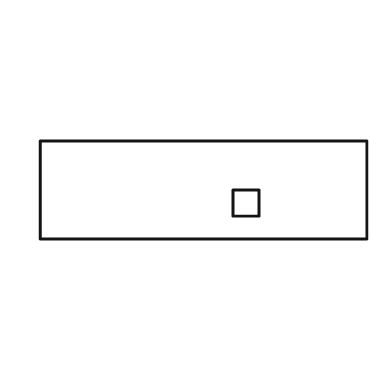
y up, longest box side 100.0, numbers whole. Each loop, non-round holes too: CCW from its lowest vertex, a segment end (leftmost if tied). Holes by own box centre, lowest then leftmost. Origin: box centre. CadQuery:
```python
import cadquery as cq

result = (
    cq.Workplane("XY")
    .moveTo(-50.0, -15.0)
    .lineTo(50.0, -15.0)
    .lineTo(50.0, 15.0)
    .lineTo(-50.0, 15.0)
    .close()
    .moveTo(9.0, -8.0)
    .lineTo(17.0, -8.0)
    .lineTo(17.0, 0.0)
    .lineTo(9.0, 0.0)
    .close()
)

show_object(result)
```